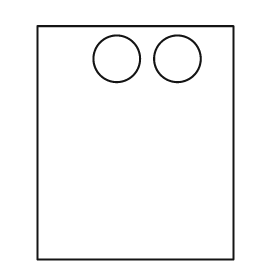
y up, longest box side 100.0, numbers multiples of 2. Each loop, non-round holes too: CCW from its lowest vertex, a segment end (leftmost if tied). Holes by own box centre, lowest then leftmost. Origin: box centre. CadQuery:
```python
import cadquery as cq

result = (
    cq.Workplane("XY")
    .moveTo(-42.0, -50.0)
    .lineTo(42.0, -50.0)
    .lineTo(42.0, 50.0)
    .lineTo(-42.0, 50.0)
    .close()
    .moveTo(-8.0, 36.0)
    .circle(10.0)
    .moveTo(18.0, 36.0)
    .circle(10.0)
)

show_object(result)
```